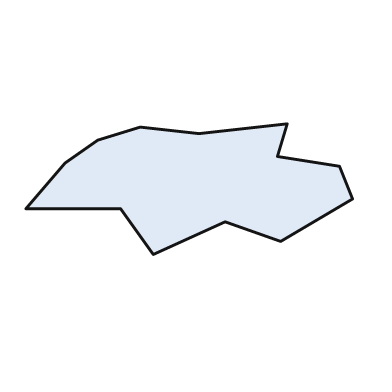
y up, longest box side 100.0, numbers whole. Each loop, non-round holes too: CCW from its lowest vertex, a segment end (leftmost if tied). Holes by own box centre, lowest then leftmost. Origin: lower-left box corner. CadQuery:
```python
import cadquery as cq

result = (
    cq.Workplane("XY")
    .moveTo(39.0, 0.0)
    .lineTo(61.0, 10.0)
    .lineTo(78.0, 4.0)
    .lineTo(100.0, 17.0)
    .lineTo(96.0, 27.0)
    .lineTo(77.0, 30.0)
    .lineTo(80.0, 40.0)
    .lineTo(53.0, 37.0)
    .lineTo(35.0, 39.0)
    .lineTo(22.0, 35.0)
    .lineTo(12.0, 28.0)
    .lineTo(0.0, 14.0)
    .lineTo(29.0, 14.0)
    .close()
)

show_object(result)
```